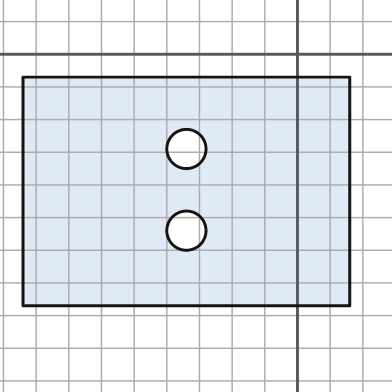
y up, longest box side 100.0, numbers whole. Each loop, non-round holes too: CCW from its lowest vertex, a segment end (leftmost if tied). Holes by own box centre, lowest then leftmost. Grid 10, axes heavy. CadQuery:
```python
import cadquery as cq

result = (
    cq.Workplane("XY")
    .moveTo(-84.0, -77.0)
    .lineTo(16.0, -77.0)
    .lineTo(16.0, -7.0)
    .lineTo(-84.0, -7.0)
    .close()
    .moveTo(-34.0, -54.0)
    .circle(6.0)
    .moveTo(-34.0, -29.0)
    .circle(6.0)
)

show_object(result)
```